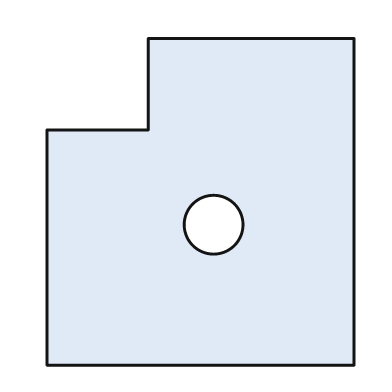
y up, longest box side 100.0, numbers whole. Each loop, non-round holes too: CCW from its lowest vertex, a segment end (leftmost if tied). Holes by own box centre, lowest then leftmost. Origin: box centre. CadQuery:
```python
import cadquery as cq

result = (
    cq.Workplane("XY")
    .moveTo(-47.0, -50.0)
    .lineTo(47.0, -50.0)
    .lineTo(47.0, 50.0)
    .lineTo(-16.0, 50.0)
    .lineTo(-16.0, 22.0)
    .lineTo(-47.0, 22.0)
    .close()
    .moveTo(4.0, -7.0)
    .circle(9.0)
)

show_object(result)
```